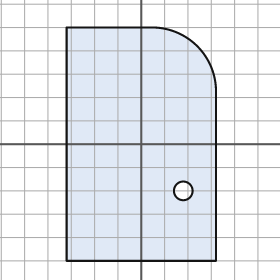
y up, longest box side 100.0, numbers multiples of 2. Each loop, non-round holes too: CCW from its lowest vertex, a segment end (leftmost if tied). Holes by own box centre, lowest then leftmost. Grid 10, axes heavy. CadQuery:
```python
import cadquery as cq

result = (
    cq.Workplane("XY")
    .moveTo(-32.0, -50.0)
    .lineTo(32.0, -50.0)
    .lineTo(32.0, 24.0)
    .threePointArc((24.0, 42.0), (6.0, 50.0))
    .lineTo(-32.0, 50.0)
    .close()
    .moveTo(18.0, -20.0)
    .circle(4.0)
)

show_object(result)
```